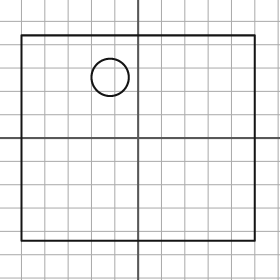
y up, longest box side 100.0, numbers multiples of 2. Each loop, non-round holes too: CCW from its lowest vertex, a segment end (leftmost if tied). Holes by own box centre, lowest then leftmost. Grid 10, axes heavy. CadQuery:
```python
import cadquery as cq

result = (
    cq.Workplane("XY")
    .moveTo(-50.0, -44.0)
    .lineTo(50.0, -44.0)
    .lineTo(50.0, 44.0)
    .lineTo(-50.0, 44.0)
    .close()
    .moveTo(-12.0, 26.0)
    .circle(8.0)
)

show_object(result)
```